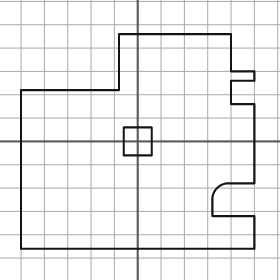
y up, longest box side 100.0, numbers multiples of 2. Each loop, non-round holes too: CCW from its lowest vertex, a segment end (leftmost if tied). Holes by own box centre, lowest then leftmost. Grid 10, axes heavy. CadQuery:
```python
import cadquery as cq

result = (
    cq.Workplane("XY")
    .moveTo(-50.0, -46.0)
    .lineTo(50.0, -46.0)
    .lineTo(50.0, -32.0)
    .lineTo(32.0, -32.0)
    .lineTo(32.0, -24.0)
    .threePointArc((34.0, -20.0), (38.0, -18.0))
    .lineTo(50.0, -18.0)
    .lineTo(50.0, 16.0)
    .lineTo(40.0, 16.0)
    .lineTo(40.0, 26.0)
    .lineTo(50.0, 26.0)
    .lineTo(50.0, 30.0)
    .lineTo(40.0, 30.0)
    .lineTo(40.0, 46.0)
    .lineTo(-8.0, 46.0)
    .lineTo(-8.0, 22.0)
    .lineTo(-50.0, 22.0)
    .close()
    .moveTo(-6.0, -6.0)
    .lineTo(6.0, -6.0)
    .lineTo(6.0, 6.0)
    .lineTo(-6.0, 6.0)
    .close()
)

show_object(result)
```